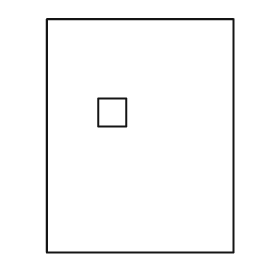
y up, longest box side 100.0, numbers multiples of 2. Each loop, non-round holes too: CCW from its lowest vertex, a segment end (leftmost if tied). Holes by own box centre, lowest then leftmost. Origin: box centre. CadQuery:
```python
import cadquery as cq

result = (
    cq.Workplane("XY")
    .moveTo(-40.0, -50.0)
    .lineTo(40.0, -50.0)
    .lineTo(40.0, 50.0)
    .lineTo(-40.0, 50.0)
    .close()
    .moveTo(-18.0, 4.0)
    .lineTo(-6.0, 4.0)
    .lineTo(-6.0, 16.0)
    .lineTo(-18.0, 16.0)
    .close()
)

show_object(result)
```